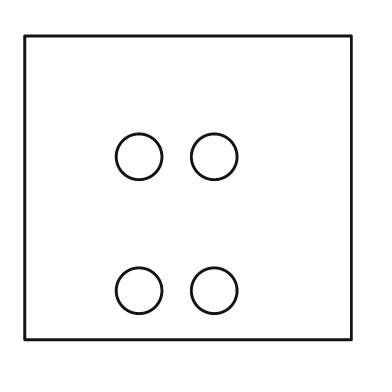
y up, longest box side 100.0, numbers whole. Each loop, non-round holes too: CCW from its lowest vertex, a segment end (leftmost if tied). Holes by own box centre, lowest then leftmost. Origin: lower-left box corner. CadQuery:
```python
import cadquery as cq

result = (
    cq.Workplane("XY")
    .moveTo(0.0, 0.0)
    .lineTo(100.0, 0.0)
    .lineTo(100.0, 93.0)
    .lineTo(0.0, 93.0)
    .close()
    .moveTo(35.0, 15.0)
    .circle(7.0)
    .moveTo(58.0, 15.0)
    .circle(7.0)
    .moveTo(35.0, 56.0)
    .circle(7.0)
    .moveTo(58.0, 56.0)
    .circle(7.0)
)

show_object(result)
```